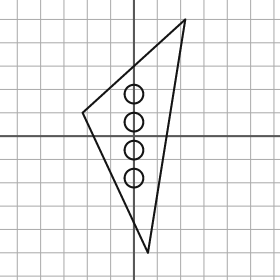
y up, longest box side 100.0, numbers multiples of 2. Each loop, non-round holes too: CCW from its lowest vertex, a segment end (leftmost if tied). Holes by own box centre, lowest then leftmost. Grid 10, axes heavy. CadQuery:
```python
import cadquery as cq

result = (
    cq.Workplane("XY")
    .moveTo(6.0, -50.0)
    .lineTo(22.0, 50.0)
    .lineTo(-22.0, 10.0)
    .close()
    .moveTo(0.0, -18.0)
    .circle(4.0)
    .moveTo(0.0, -6.0)
    .circle(4.0)
    .moveTo(0.0, 6.0)
    .circle(4.0)
    .moveTo(0.0, 18.0)
    .circle(4.0)
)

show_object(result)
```